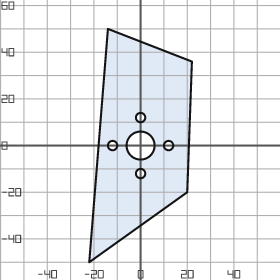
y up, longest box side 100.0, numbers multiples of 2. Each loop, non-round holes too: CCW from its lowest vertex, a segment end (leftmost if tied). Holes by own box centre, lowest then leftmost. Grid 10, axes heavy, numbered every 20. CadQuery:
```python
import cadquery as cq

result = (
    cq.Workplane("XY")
    .moveTo(-22.0, -50.0)
    .lineTo(20.0, -20.0)
    .lineTo(22.0, 36.0)
    .lineTo(-14.0, 50.0)
    .close()
    .moveTo(0.0, -12.0)
    .circle(2.0)
    .moveTo(-12.0, 0.0)
    .circle(2.0)
    .moveTo(0.0, 0.0)
    .circle(6.0)
    .moveTo(12.0, 0.0)
    .circle(2.0)
    .moveTo(0.0, 12.0)
    .circle(2.0)
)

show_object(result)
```